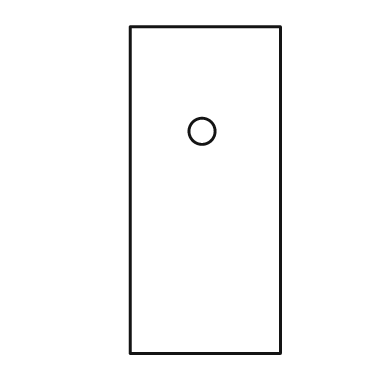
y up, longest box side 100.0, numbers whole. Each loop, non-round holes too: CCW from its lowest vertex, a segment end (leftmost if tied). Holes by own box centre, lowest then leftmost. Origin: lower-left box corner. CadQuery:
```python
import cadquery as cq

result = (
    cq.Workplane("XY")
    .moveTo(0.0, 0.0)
    .lineTo(46.0, 0.0)
    .lineTo(46.0, 100.0)
    .lineTo(0.0, 100.0)
    .close()
    .moveTo(22.0, 68.0)
    .circle(4.0)
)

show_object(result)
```